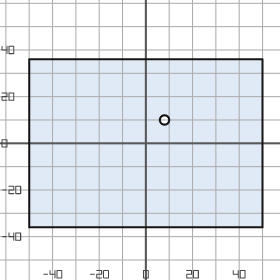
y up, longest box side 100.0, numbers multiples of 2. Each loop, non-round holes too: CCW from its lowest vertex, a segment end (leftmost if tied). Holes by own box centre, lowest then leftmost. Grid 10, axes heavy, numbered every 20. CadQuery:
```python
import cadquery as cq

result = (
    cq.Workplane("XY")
    .moveTo(-50.0, -36.0)
    .lineTo(50.0, -36.0)
    .lineTo(50.0, 36.0)
    .lineTo(-50.0, 36.0)
    .close()
    .moveTo(8.0, 10.0)
    .circle(2.0)
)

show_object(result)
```